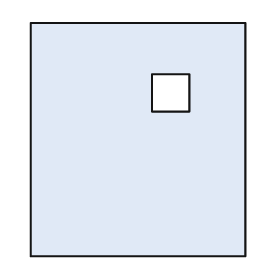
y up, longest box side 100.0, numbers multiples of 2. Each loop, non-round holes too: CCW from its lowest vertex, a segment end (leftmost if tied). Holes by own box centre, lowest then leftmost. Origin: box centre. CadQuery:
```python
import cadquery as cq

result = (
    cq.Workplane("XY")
    .moveTo(-46.0, -50.0)
    .lineTo(46.0, -50.0)
    .lineTo(46.0, 50.0)
    .lineTo(-46.0, 50.0)
    .close()
    .moveTo(6.0, 12.0)
    .lineTo(22.0, 12.0)
    .lineTo(22.0, 28.0)
    .lineTo(6.0, 28.0)
    .close()
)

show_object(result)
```